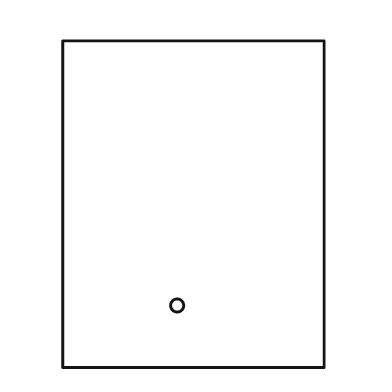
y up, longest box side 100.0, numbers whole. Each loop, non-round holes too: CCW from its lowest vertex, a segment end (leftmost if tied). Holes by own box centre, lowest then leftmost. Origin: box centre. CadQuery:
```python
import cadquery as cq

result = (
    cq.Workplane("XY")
    .moveTo(-40.0, -50.0)
    .lineTo(40.0, -50.0)
    .lineTo(40.0, 50.0)
    .lineTo(-40.0, 50.0)
    .close()
    .moveTo(-5.0, -31.0)
    .circle(2.0)
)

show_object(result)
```